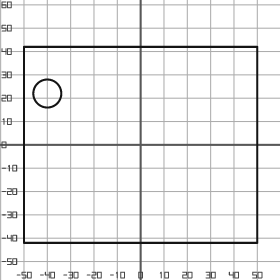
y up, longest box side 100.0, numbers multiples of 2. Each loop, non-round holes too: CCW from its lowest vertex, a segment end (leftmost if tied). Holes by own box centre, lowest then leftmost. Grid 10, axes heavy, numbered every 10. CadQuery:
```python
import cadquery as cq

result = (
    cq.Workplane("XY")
    .moveTo(-50.0, -42.0)
    .lineTo(50.0, -42.0)
    .lineTo(50.0, 42.0)
    .lineTo(-50.0, 42.0)
    .close()
    .moveTo(-40.0, 22.0)
    .circle(6.0)
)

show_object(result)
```